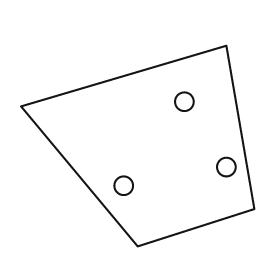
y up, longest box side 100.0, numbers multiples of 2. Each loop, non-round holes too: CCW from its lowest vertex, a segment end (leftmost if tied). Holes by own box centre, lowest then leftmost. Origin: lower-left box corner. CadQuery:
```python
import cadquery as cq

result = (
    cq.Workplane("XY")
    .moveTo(50.0, 0.0)
    .lineTo(100.0, 16.0)
    .lineTo(88.0, 86.0)
    .lineTo(0.0, 60.0)
    .close()
    .moveTo(44.0, 26.0)
    .circle(4.0)
    .moveTo(88.0, 34.0)
    .circle(4.0)
    .moveTo(70.0, 62.0)
    .circle(4.0)
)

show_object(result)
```